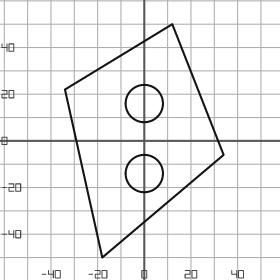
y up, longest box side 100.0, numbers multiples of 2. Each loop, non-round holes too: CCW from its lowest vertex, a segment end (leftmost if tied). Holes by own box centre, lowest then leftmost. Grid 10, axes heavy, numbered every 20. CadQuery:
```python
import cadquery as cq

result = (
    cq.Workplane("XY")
    .moveTo(-18.0, -50.0)
    .lineTo(34.0, -6.0)
    .lineTo(12.0, 50.0)
    .lineTo(-34.0, 22.0)
    .close()
    .moveTo(0.0, -14.0)
    .circle(8.0)
    .moveTo(0.0, 16.0)
    .circle(8.0)
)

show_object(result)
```